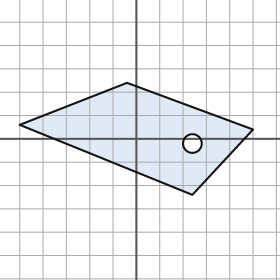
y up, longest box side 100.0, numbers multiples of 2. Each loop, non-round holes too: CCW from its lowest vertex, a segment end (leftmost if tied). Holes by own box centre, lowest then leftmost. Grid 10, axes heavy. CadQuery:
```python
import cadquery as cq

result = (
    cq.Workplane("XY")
    .moveTo(24.0, -24.0)
    .lineTo(50.0, 4.0)
    .lineTo(-4.0, 24.0)
    .lineTo(-50.0, 6.0)
    .close()
    .moveTo(24.0, -2.0)
    .circle(4.0)
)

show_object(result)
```